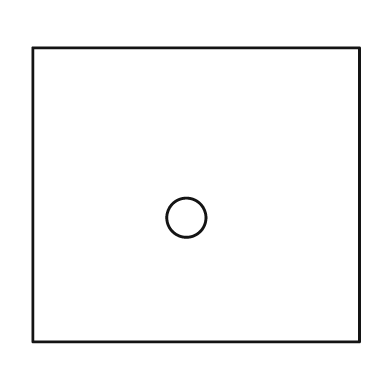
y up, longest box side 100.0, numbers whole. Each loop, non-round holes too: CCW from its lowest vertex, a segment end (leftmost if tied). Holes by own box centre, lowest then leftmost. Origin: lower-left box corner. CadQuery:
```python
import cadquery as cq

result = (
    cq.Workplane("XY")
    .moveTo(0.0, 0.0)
    .lineTo(100.0, 0.0)
    .lineTo(100.0, 90.0)
    .lineTo(0.0, 90.0)
    .close()
    .moveTo(47.0, 38.0)
    .circle(6.0)
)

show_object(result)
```